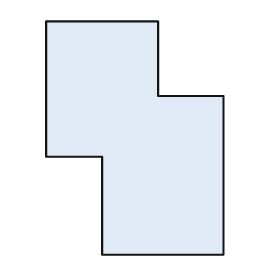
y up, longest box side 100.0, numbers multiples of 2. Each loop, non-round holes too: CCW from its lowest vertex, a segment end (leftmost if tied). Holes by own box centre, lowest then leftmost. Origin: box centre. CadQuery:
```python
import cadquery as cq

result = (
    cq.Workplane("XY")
    .moveTo(-14.0, -50.0)
    .lineTo(38.0, -50.0)
    .lineTo(38.0, 18.0)
    .lineTo(10.0, 18.0)
    .lineTo(10.0, 50.0)
    .lineTo(-38.0, 50.0)
    .lineTo(-38.0, -8.0)
    .lineTo(-14.0, -8.0)
    .close()
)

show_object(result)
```